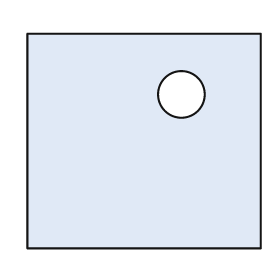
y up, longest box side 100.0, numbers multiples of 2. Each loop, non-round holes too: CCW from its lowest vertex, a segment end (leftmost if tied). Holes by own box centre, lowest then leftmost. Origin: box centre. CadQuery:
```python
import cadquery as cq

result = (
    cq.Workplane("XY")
    .moveTo(-50.0, -46.0)
    .lineTo(50.0, -46.0)
    .lineTo(50.0, 46.0)
    .lineTo(-50.0, 46.0)
    .close()
    .moveTo(16.0, 20.0)
    .circle(10.0)
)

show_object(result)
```